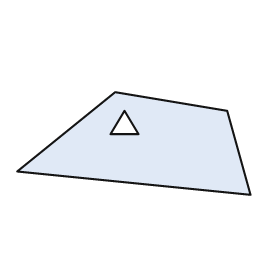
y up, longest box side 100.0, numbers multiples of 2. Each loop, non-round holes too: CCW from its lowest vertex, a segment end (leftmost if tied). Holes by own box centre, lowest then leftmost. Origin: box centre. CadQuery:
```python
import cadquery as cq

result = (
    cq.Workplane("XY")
    .moveTo(50.0, -22.0)
    .lineTo(40.0, 14.0)
    .lineTo(-8.0, 22.0)
    .lineTo(-50.0, -12.0)
    .close()
    .moveTo(-10.0, 4.0)
    .lineTo(2.0, 4.0)
    .lineTo(-4.0, 14.0)
    .close()
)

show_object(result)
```